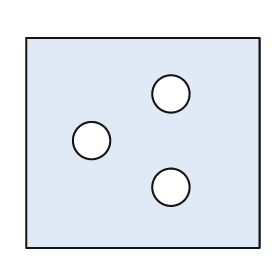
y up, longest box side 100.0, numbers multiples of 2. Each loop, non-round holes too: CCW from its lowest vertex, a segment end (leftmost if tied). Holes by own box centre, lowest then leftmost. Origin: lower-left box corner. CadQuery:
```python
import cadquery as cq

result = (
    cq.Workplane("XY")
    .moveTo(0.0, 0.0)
    .lineTo(100.0, 0.0)
    .lineTo(100.0, 90.0)
    .lineTo(0.0, 90.0)
    .close()
    .moveTo(62.0, 26.0)
    .circle(8.0)
    .moveTo(28.0, 46.0)
    .circle(8.0)
    .moveTo(62.0, 66.0)
    .circle(8.0)
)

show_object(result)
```